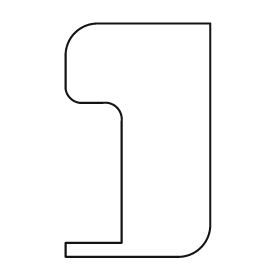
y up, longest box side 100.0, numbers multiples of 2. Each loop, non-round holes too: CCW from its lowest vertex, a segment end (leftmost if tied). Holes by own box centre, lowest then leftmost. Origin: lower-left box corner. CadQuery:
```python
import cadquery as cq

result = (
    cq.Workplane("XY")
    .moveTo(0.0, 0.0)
    .lineTo(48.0, 0.0)
    .threePointArc((58.0, 4.0), (62.0, 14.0))
    .lineTo(62.0, 100.0)
    .lineTo(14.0, 100.0)
    .threePointArc((4.0, 96.0), (0.0, 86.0))
    .lineTo(0.0, 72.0)
    .threePointArc((2.0, 68.0), (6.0, 66.0))
    .lineTo(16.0, 66.0)
    .threePointArc((22.0, 64.0), (24.0, 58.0))
    .lineTo(24.0, 6.0)
    .lineTo(0.0, 6.0)
    .close()
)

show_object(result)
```